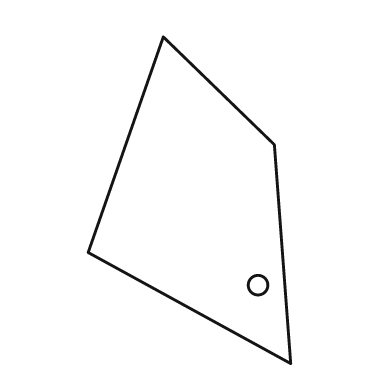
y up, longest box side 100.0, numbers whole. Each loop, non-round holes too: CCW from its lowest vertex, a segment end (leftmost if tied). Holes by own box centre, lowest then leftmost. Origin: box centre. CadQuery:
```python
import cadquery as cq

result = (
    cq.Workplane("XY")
    .moveTo(31.0, -50.0)
    .lineTo(26.0, 17.0)
    .lineTo(-8.0, 50.0)
    .lineTo(-31.0, -16.0)
    .close()
    .moveTo(21.0, -26.0)
    .circle(3.0)
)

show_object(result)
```